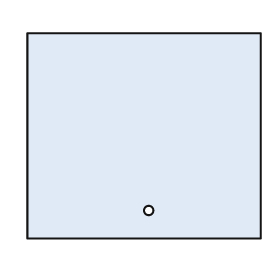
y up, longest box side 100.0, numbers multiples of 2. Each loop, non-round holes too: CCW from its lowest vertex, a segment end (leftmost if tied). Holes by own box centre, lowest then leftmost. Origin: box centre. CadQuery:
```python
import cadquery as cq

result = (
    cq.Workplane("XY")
    .moveTo(-50.0, -44.0)
    .lineTo(50.0, -44.0)
    .lineTo(50.0, 44.0)
    .lineTo(-50.0, 44.0)
    .close()
    .moveTo(2.0, -32.0)
    .circle(2.0)
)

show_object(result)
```